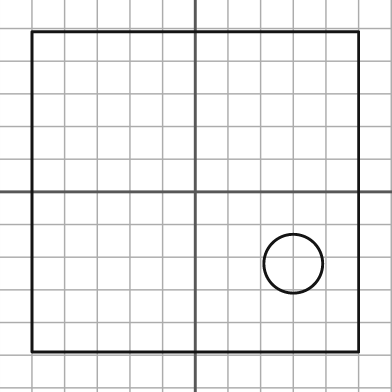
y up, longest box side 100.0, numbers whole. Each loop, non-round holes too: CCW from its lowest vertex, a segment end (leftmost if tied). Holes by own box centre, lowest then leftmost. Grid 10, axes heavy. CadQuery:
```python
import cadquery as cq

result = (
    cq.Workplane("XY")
    .moveTo(-50.0, -49.0)
    .lineTo(50.0, -49.0)
    .lineTo(50.0, 49.0)
    .lineTo(-50.0, 49.0)
    .close()
    .moveTo(30.0, -22.0)
    .circle(9.0)
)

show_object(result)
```